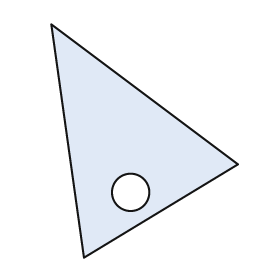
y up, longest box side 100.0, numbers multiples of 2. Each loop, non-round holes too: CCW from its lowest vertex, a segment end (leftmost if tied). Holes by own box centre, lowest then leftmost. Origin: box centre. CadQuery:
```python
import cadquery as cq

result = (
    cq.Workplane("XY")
    .moveTo(-26.0, -50.0)
    .lineTo(40.0, -10.0)
    .lineTo(-40.0, 50.0)
    .close()
    .moveTo(-6.0, -22.0)
    .circle(8.0)
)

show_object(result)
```